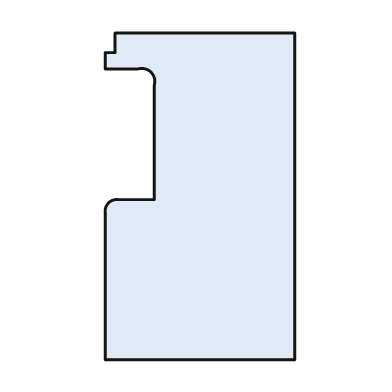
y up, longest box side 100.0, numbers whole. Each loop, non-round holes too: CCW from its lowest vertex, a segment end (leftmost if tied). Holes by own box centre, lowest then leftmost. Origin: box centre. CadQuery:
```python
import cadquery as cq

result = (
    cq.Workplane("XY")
    .moveTo(-29.0, -50.0)
    .lineTo(29.0, -50.0)
    .lineTo(29.0, 50.0)
    .lineTo(-26.0, 50.0)
    .lineTo(-26.0, 44.0)
    .lineTo(-29.0, 44.0)
    .lineTo(-29.0, 39.0)
    .lineTo(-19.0, 39.0)
    .threePointArc((-15.0, 38.0), (-14.0, 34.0))
    .lineTo(-14.0, -1.0)
    .lineTo(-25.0, -1.0)
    .threePointArc((-28.0, -2.0), (-29.0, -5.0))
    .close()
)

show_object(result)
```